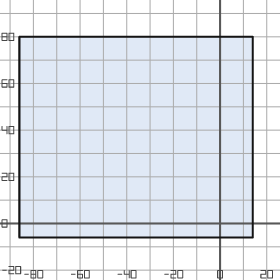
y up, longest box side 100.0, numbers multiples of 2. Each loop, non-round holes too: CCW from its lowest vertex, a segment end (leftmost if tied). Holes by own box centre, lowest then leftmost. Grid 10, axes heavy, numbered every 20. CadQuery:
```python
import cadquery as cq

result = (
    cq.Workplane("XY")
    .moveTo(-86.0, -6.0)
    .lineTo(14.0, -6.0)
    .lineTo(14.0, 80.0)
    .lineTo(-86.0, 80.0)
    .close()
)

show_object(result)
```